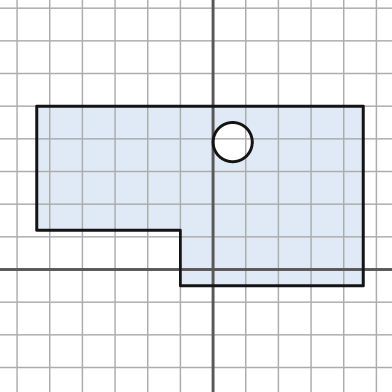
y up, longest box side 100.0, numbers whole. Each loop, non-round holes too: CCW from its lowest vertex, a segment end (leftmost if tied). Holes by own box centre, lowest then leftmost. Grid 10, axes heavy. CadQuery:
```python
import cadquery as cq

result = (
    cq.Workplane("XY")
    .moveTo(-10.0, -5.0)
    .lineTo(46.0, -5.0)
    .lineTo(46.0, 50.0)
    .lineTo(-54.0, 50.0)
    .lineTo(-54.0, 12.0)
    .lineTo(-10.0, 12.0)
    .close()
    .moveTo(6.0, 39.0)
    .circle(6.0)
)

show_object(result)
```